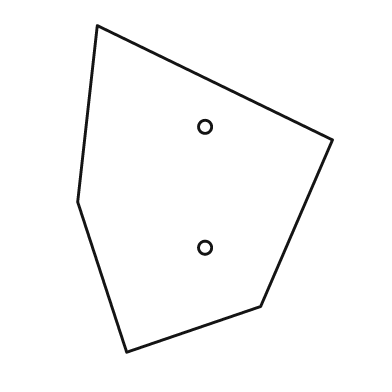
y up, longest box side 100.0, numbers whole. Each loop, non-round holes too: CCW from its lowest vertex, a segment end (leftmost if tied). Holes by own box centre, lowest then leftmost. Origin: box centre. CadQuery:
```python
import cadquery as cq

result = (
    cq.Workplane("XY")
    .moveTo(-24.0, -50.0)
    .lineTo(17.0, -36.0)
    .lineTo(39.0, 15.0)
    .lineTo(-33.0, 50.0)
    .lineTo(-39.0, -4.0)
    .close()
    .moveTo(0.0, -18.0)
    .circle(2.0)
    .moveTo(0.0, 19.0)
    .circle(2.0)
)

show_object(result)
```